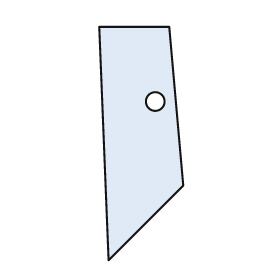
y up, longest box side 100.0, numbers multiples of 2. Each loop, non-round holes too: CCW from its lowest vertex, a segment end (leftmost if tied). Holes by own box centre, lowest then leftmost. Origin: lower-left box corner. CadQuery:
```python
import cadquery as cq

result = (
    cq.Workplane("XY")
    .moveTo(4.0, 0.0)
    .lineTo(36.0, 32.0)
    .lineTo(30.0, 100.0)
    .lineTo(0.0, 100.0)
    .close()
    .moveTo(24.0, 68.0)
    .circle(4.0)
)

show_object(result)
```